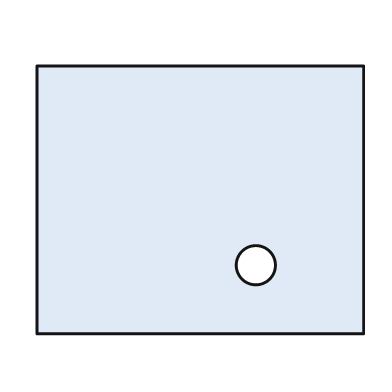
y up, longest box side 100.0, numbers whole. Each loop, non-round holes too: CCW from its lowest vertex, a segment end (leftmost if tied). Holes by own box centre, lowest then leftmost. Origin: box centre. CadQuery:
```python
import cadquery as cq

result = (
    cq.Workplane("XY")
    .moveTo(-50.0, -41.0)
    .lineTo(50.0, -41.0)
    .lineTo(50.0, 41.0)
    .lineTo(-50.0, 41.0)
    .close()
    .moveTo(17.0, -20.0)
    .circle(6.0)
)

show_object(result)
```